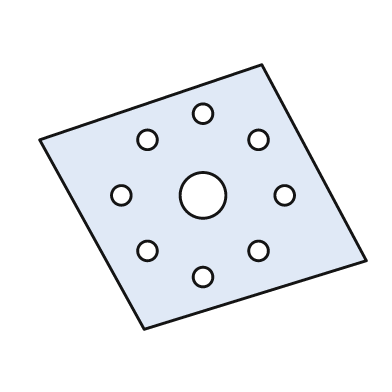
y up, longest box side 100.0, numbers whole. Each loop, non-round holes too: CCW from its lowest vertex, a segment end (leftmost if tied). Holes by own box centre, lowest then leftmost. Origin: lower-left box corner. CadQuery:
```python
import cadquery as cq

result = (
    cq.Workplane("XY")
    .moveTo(32.0, 0.0)
    .lineTo(100.0, 21.0)
    .lineTo(68.0, 81.0)
    .lineTo(0.0, 58.0)
    .close()
    .moveTo(50.0, 16.0)
    .circle(3.0)
    .moveTo(33.0, 24.0)
    .circle(3.0)
    .moveTo(67.0, 24.0)
    .circle(3.0)
    .moveTo(25.0, 41.0)
    .circle(3.0)
    .moveTo(50.0, 41.0)
    .circle(7.0)
    .moveTo(75.0, 41.0)
    .circle(3.0)
    .moveTo(33.0, 58.0)
    .circle(3.0)
    .moveTo(67.0, 58.0)
    .circle(3.0)
    .moveTo(50.0, 66.0)
    .circle(3.0)
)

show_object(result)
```